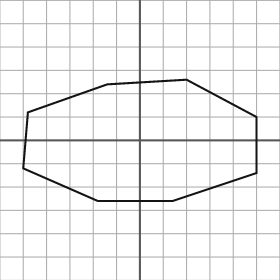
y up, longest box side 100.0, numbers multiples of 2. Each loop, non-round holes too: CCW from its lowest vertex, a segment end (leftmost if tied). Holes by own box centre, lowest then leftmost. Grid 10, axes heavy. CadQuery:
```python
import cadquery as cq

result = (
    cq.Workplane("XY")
    .moveTo(-18.0, -26.0)
    .lineTo(14.0, -26.0)
    .lineTo(50.0, -14.0)
    .lineTo(50.0, 10.0)
    .lineTo(20.0, 26.0)
    .lineTo(-14.0, 24.0)
    .lineTo(-48.0, 12.0)
    .lineTo(-50.0, -12.0)
    .close()
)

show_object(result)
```